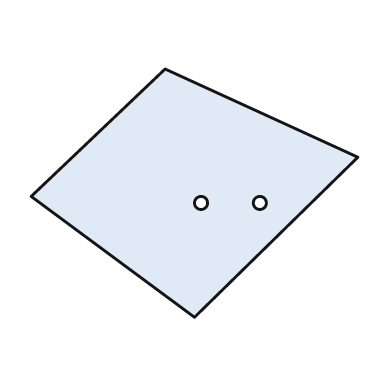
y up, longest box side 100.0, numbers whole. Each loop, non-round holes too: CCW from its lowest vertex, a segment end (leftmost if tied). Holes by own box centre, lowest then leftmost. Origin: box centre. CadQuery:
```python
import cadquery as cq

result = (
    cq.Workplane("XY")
    .moveTo(0.0, -38.0)
    .lineTo(50.0, 11.0)
    .lineTo(-9.0, 38.0)
    .lineTo(-50.0, -1.0)
    .close()
    .moveTo(2.0, -3.0)
    .circle(2.0)
    .moveTo(20.0, -3.0)
    .circle(2.0)
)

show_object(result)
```